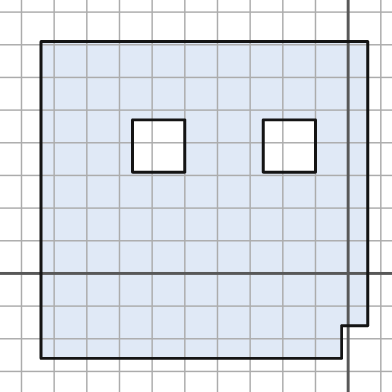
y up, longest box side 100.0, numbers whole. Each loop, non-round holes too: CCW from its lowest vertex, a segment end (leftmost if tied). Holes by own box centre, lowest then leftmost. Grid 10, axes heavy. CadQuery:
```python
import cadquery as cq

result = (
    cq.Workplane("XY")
    .moveTo(-94.0, -26.0)
    .lineTo(-2.0, -26.0)
    .lineTo(-2.0, -16.0)
    .lineTo(6.0, -16.0)
    .lineTo(6.0, 71.0)
    .lineTo(-94.0, 71.0)
    .close()
    .moveTo(-66.0, 31.0)
    .lineTo(-50.0, 31.0)
    .lineTo(-50.0, 47.0)
    .lineTo(-66.0, 47.0)
    .close()
    .moveTo(-26.0, 31.0)
    .lineTo(-10.0, 31.0)
    .lineTo(-10.0, 47.0)
    .lineTo(-26.0, 47.0)
    .close()
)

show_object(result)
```